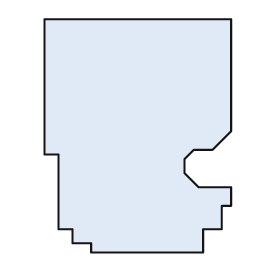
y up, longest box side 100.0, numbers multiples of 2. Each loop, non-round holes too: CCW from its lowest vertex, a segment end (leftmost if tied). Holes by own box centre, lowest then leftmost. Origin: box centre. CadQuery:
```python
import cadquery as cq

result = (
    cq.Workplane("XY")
    .moveTo(-20.0, -50.0)
    .lineTo(28.0, -50.0)
    .lineTo(28.0, -40.0)
    .lineTo(36.0, -40.0)
    .lineTo(36.0, -30.0)
    .lineTo(40.0, -30.0)
    .lineTo(40.0, -22.0)
    .lineTo(26.0, -22.0)
    .lineTo(20.0, -16.0)
    .lineTo(20.0, -10.0)
    .lineTo(24.0, -6.0)
    .lineTo(32.0, -6.0)
    .lineTo(40.0, 2.0)
    .lineTo(40.0, 50.0)
    .lineTo(-40.0, 50.0)
    .lineTo(-40.0, -8.0)
    .lineTo(-34.0, -8.0)
    .lineTo(-34.0, -40.0)
    .lineTo(-28.0, -40.0)
    .lineTo(-28.0, -46.0)
    .lineTo(-20.0, -46.0)
    .close()
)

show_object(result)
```